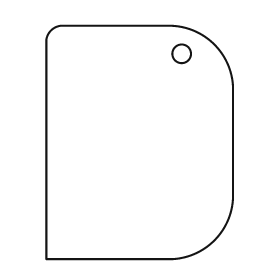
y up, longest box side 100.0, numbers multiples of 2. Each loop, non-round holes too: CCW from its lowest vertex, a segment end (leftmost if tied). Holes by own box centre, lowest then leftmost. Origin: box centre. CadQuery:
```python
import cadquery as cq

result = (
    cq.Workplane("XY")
    .moveTo(-40.0, -50.0)
    .lineTo(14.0, -50.0)
    .threePointArc((32.0, -42.0), (40.0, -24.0))
    .lineTo(40.0, 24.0)
    .threePointArc((32.0, 42.0), (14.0, 50.0))
    .lineTo(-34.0, 50.0)
    .threePointArc((-38.0, 48.0), (-40.0, 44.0))
    .close()
    .moveTo(18.0, 38.0)
    .circle(4.0)
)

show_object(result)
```